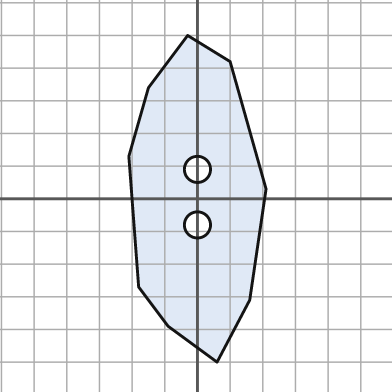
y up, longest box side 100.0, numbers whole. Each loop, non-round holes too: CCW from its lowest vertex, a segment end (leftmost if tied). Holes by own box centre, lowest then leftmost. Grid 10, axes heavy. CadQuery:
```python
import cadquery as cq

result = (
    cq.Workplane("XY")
    .moveTo(6.0, -50.0)
    .lineTo(16.0, -31.0)
    .lineTo(21.0, 3.0)
    .lineTo(10.0, 42.0)
    .lineTo(-3.0, 50.0)
    .lineTo(-15.0, 34.0)
    .lineTo(-21.0, 13.0)
    .lineTo(-18.0, -27.0)
    .lineTo(-9.0, -39.0)
    .close()
    .moveTo(0.0, -8.0)
    .circle(4.0)
    .moveTo(0.0, 9.0)
    .circle(4.0)
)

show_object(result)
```